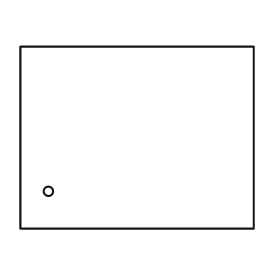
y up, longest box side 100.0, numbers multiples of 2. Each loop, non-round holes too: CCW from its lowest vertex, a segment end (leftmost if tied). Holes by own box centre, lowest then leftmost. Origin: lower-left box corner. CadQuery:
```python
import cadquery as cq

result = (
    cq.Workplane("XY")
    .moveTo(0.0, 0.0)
    .lineTo(100.0, 0.0)
    .lineTo(100.0, 78.0)
    .lineTo(0.0, 78.0)
    .close()
    .moveTo(12.0, 16.0)
    .circle(2.0)
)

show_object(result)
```